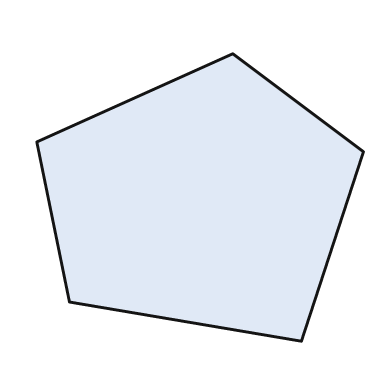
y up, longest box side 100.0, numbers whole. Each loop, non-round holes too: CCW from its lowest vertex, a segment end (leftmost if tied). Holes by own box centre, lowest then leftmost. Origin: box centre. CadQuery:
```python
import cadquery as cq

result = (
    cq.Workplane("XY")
    .moveTo(31.0, -44.0)
    .lineTo(50.0, 14.0)
    .lineTo(10.0, 44.0)
    .lineTo(-50.0, 17.0)
    .lineTo(-40.0, -32.0)
    .close()
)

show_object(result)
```